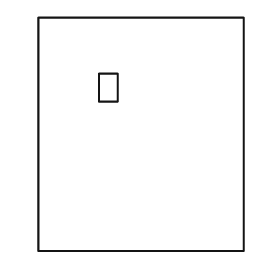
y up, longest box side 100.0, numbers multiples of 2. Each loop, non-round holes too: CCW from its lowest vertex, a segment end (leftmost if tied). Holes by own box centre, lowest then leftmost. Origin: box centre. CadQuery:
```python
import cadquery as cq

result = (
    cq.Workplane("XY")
    .moveTo(-44.0, -50.0)
    .lineTo(44.0, -50.0)
    .lineTo(44.0, 50.0)
    .lineTo(-44.0, 50.0)
    .close()
    .moveTo(-18.0, 14.0)
    .lineTo(-10.0, 14.0)
    .lineTo(-10.0, 26.0)
    .lineTo(-18.0, 26.0)
    .close()
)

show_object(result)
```